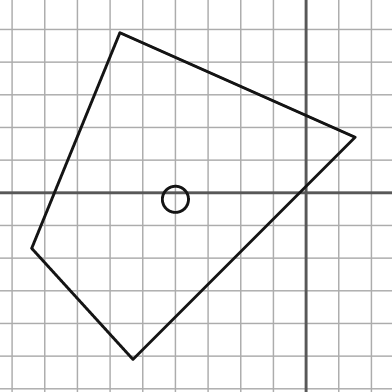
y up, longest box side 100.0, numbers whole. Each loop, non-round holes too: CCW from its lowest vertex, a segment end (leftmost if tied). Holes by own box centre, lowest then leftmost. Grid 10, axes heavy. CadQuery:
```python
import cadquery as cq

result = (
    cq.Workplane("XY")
    .moveTo(-53.0, -51.0)
    .lineTo(15.0, 17.0)
    .lineTo(-57.0, 49.0)
    .lineTo(-84.0, -17.0)
    .close()
    .moveTo(-40.0, -2.0)
    .circle(4.0)
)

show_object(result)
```